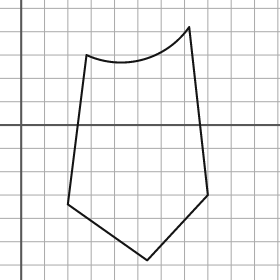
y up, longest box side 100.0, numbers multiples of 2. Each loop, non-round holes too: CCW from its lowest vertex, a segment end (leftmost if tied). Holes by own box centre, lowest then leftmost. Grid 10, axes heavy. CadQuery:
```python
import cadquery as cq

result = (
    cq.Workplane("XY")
    .moveTo(54.0, -58.0)
    .lineTo(80.0, -30.0)
    .lineTo(72.0, 42.0)
    .threePointArc((52.0, 28.0), (28.0, 30.0))
    .lineTo(20.0, -34.0)
    .close()
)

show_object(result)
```